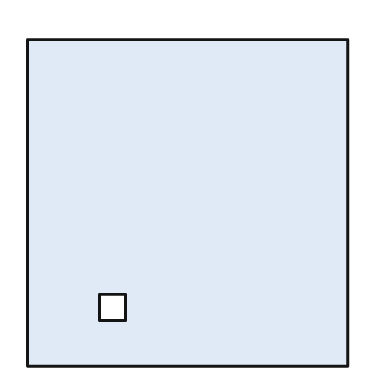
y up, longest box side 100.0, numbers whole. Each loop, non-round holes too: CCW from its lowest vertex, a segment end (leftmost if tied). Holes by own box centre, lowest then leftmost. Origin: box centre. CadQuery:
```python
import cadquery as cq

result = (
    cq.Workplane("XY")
    .moveTo(-49.0, -50.0)
    .lineTo(49.0, -50.0)
    .lineTo(49.0, 50.0)
    .lineTo(-49.0, 50.0)
    .close()
    .moveTo(-27.0, -36.0)
    .lineTo(-19.0, -36.0)
    .lineTo(-19.0, -28.0)
    .lineTo(-27.0, -28.0)
    .close()
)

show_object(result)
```